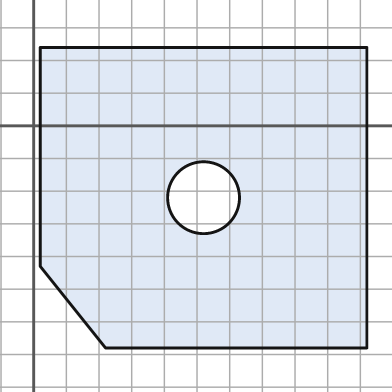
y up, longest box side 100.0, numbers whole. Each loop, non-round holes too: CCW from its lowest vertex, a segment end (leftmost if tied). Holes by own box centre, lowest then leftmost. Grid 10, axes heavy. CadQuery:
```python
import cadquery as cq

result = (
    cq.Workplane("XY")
    .moveTo(22.0, -68.0)
    .lineTo(102.0, -68.0)
    .lineTo(102.0, 24.0)
    .lineTo(2.0, 24.0)
    .lineTo(2.0, -43.0)
    .close()
    .moveTo(52.0, -22.0)
    .circle(11.0)
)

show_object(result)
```